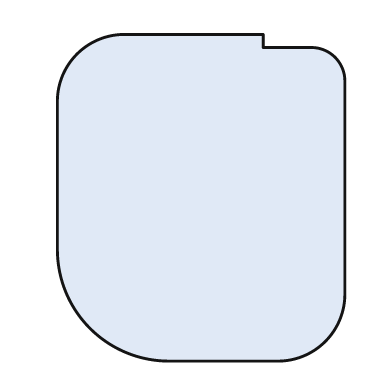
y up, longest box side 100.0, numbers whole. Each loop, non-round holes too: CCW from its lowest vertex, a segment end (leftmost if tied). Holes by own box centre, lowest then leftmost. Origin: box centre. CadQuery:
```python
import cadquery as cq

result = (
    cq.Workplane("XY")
    .moveTo(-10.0, -50.0)
    .lineTo(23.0, -50.0)
    .threePointArc((38.0, -44.0), (44.0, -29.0))
    .lineTo(44.0, 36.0)
    .threePointArc((41.0, 43.0), (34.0, 46.0))
    .lineTo(19.0, 46.0)
    .lineTo(19.0, 50.0)
    .lineTo(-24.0, 50.0)
    .threePointArc((-38.0, 44.0), (-44.0, 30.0))
    .lineTo(-44.0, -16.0)
    .threePointArc((-34.0, -40.0), (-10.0, -50.0))
    .close()
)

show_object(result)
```